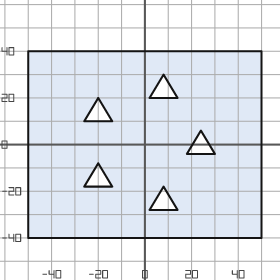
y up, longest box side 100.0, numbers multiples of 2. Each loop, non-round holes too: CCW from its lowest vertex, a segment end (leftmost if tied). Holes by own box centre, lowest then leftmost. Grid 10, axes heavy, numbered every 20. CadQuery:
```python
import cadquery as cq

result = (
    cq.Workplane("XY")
    .moveTo(-50.0, -40.0)
    .lineTo(50.0, -40.0)
    .lineTo(50.0, 40.0)
    .lineTo(-50.0, 40.0)
    .close()
    .moveTo(2.0, -28.0)
    .lineTo(14.0, -28.0)
    .lineTo(8.0, -18.0)
    .close()
    .moveTo(-26.0, -18.0)
    .lineTo(-14.0, -18.0)
    .lineTo(-20.0, -8.0)
    .close()
    .moveTo(18.0, -4.0)
    .lineTo(30.0, -4.0)
    .lineTo(24.0, 6.0)
    .close()
    .moveTo(-26.0, 10.0)
    .lineTo(-14.0, 10.0)
    .lineTo(-20.0, 20.0)
    .close()
    .moveTo(2.0, 20.0)
    .lineTo(14.0, 20.0)
    .lineTo(8.0, 30.0)
    .close()
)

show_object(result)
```